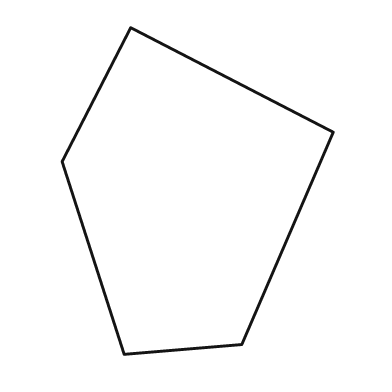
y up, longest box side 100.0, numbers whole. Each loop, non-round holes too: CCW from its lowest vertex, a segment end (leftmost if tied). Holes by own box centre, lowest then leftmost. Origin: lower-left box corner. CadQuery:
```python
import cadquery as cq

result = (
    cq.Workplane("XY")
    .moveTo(19.0, 0.0)
    .lineTo(55.0, 3.0)
    .lineTo(83.0, 68.0)
    .lineTo(21.0, 100.0)
    .lineTo(0.0, 59.0)
    .close()
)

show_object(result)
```